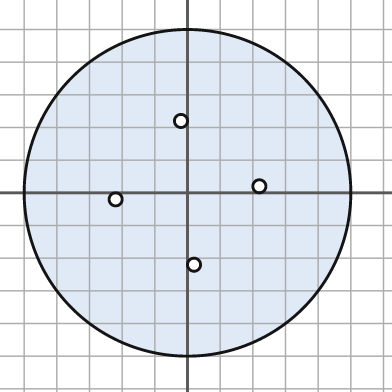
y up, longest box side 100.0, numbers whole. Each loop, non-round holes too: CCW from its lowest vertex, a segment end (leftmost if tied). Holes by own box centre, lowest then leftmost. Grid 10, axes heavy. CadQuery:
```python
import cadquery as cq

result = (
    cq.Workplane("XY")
    .moveTo(0.0, 0.0)
    .circle(50.0)
    .moveTo(2.0, -22.0)
    .circle(2.0)
    .moveTo(-22.0, -2.0)
    .circle(2.0)
    .moveTo(22.0, 2.0)
    .circle(2.0)
    .moveTo(-2.0, 22.0)
    .circle(2.0)
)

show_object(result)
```